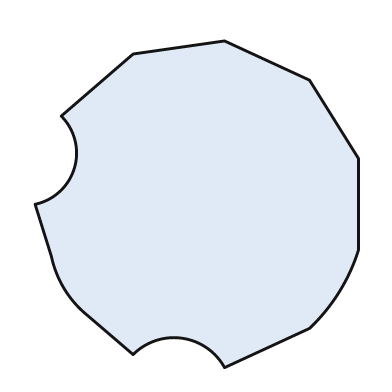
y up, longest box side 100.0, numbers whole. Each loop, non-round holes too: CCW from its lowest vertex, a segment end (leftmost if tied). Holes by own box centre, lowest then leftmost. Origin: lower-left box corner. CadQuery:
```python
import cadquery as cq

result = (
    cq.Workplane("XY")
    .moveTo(58.0, 0.0)
    .lineTo(84.0, 12.0)
    .threePointArc((93.0, 23.0), (99.0, 36.0))
    .lineTo(99.0, 64.0)
    .lineTo(84.0, 88.0)
    .lineTo(58.0, 100.0)
    .lineTo(30.0, 96.0)
    .lineTo(8.0, 77.0)
    .threePointArc((12.0, 61.0), (0.0, 50.0))
    .lineTo(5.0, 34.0)
    .threePointArc((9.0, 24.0), (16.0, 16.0))
    .lineTo(30.0, 4.0)
    .threePointArc((45.0, 9.0), (58.0, 0.0))
    .close()
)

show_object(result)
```